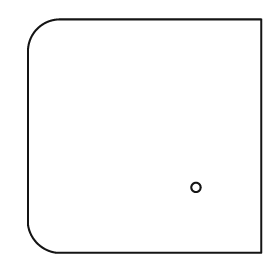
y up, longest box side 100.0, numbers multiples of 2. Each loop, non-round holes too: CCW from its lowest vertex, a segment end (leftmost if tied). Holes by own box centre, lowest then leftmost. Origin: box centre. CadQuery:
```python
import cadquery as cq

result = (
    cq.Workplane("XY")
    .moveTo(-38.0, -50.0)
    .lineTo(50.0, -50.0)
    .lineTo(50.0, 50.0)
    .lineTo(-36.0, 50.0)
    .threePointArc((-46.0, 46.0), (-50.0, 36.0))
    .lineTo(-50.0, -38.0)
    .threePointArc((-46.0, -46.0), (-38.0, -50.0))
    .close()
    .moveTo(22.0, -22.0)
    .circle(2.0)
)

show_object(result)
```